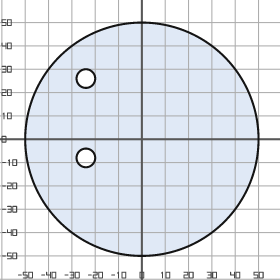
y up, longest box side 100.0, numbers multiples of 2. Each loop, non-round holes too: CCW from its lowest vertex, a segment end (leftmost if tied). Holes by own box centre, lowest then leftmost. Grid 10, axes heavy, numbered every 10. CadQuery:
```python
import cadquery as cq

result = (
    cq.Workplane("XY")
    .moveTo(0.0, 0.0)
    .circle(50.0)
    .moveTo(-24.0, -8.0)
    .circle(4.0)
    .moveTo(-24.0, 26.0)
    .circle(4.0)
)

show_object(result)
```